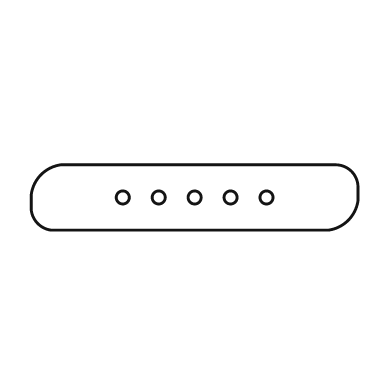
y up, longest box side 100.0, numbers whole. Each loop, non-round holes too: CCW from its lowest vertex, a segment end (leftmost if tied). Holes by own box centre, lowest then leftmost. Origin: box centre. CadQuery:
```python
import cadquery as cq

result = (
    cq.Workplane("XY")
    .moveTo(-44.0, -10.0)
    .lineTo(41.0, -10.0)
    .threePointArc((47.0, -7.0), (50.0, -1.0))
    .lineTo(50.0, 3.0)
    .threePointArc((48.0, 8.0), (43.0, 10.0))
    .lineTo(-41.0, 10.0)
    .threePointArc((-47.0, 7.0), (-50.0, 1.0))
    .lineTo(-50.0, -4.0)
    .threePointArc((-48.0, -8.0), (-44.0, -10.0))
    .close()
    .moveTo(-22.0, 0.0)
    .circle(2.0)
    .moveTo(-11.0, 0.0)
    .circle(2.0)
    .moveTo(0.0, 0.0)
    .circle(2.0)
    .moveTo(11.0, 0.0)
    .circle(2.0)
    .moveTo(22.0, 0.0)
    .circle(2.0)
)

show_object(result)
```